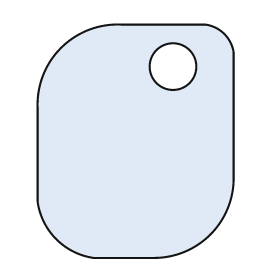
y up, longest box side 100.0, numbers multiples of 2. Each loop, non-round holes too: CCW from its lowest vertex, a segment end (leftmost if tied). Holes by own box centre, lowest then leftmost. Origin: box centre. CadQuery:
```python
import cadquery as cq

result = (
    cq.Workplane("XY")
    .moveTo(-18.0, -50.0)
    .lineTo(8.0, -50.0)
    .threePointArc((32.0, -40.0), (42.0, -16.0))
    .lineTo(42.0, 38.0)
    .threePointArc((38.0, 46.0), (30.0, 50.0))
    .lineTo(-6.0, 50.0)
    .threePointArc((-32.0, 40.0), (-42.0, 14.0))
    .lineTo(-42.0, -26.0)
    .threePointArc((-34.0, -42.0), (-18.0, -50.0))
    .close()
    .moveTo(16.0, 32.0)
    .circle(10.0)
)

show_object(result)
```